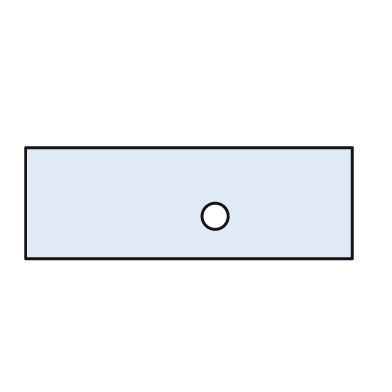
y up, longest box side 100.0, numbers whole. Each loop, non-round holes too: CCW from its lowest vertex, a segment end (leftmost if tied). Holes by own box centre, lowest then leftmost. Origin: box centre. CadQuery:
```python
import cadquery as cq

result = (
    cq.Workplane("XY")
    .moveTo(-50.0, -17.0)
    .lineTo(50.0, -17.0)
    .lineTo(50.0, 17.0)
    .lineTo(-50.0, 17.0)
    .close()
    .moveTo(8.0, -4.0)
    .circle(4.0)
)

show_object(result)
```